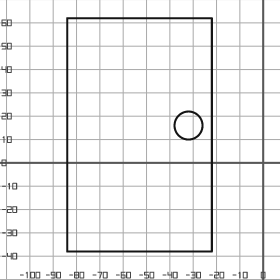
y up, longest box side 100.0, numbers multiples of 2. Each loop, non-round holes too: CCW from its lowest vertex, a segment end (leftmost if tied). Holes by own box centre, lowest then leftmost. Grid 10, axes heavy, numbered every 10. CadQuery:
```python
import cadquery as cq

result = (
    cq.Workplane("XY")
    .moveTo(-84.0, -38.0)
    .lineTo(-22.0, -38.0)
    .lineTo(-22.0, 62.0)
    .lineTo(-84.0, 62.0)
    .close()
    .moveTo(-32.0, 16.0)
    .circle(6.0)
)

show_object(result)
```